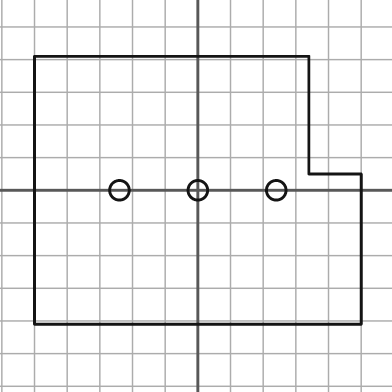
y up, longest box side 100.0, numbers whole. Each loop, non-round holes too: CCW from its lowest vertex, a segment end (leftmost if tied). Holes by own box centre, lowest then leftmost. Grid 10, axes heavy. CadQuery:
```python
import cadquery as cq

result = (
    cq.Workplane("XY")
    .moveTo(-50.0, -41.0)
    .lineTo(50.0, -41.0)
    .lineTo(50.0, 5.0)
    .lineTo(34.0, 5.0)
    .lineTo(34.0, 41.0)
    .lineTo(-50.0, 41.0)
    .close()
    .moveTo(-24.0, 0.0)
    .circle(3.0)
    .moveTo(0.0, 0.0)
    .circle(3.0)
    .moveTo(24.0, 0.0)
    .circle(3.0)
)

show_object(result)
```